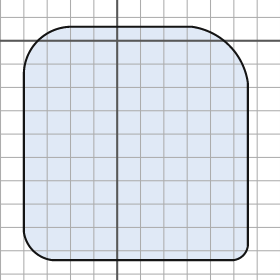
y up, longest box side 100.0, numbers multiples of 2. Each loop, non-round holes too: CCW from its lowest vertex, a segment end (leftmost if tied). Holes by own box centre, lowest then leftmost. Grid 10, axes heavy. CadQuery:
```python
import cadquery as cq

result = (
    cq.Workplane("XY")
    .moveTo(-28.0, -94.0)
    .lineTo(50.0, -94.0)
    .threePointArc((54.0, -92.0), (56.0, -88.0))
    .lineTo(56.0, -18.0)
    .threePointArc((48.0, -2.0), (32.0, 6.0))
    .lineTo(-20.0, 6.0)
    .threePointArc((-34.0, 0.0), (-40.0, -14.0))
    .lineTo(-40.0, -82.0)
    .threePointArc((-36.0, -90.0), (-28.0, -94.0))
    .close()
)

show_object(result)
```